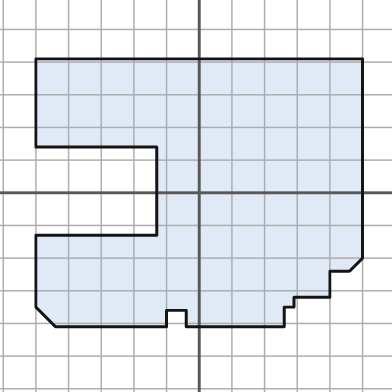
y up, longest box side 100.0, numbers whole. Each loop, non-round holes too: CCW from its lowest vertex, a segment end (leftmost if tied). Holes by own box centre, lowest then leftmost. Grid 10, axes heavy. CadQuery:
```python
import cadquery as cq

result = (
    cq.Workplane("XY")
    .moveTo(-44.0, -41.0)
    .lineTo(-10.0, -41.0)
    .lineTo(-10.0, -36.0)
    .lineTo(-4.0, -36.0)
    .lineTo(-4.0, -41.0)
    .lineTo(26.0, -41.0)
    .lineTo(26.0, -35.0)
    .lineTo(29.0, -35.0)
    .lineTo(29.0, -32.0)
    .lineTo(40.0, -32.0)
    .lineTo(40.0, -24.0)
    .lineTo(46.0, -24.0)
    .lineTo(50.0, -20.0)
    .lineTo(50.0, 41.0)
    .lineTo(-50.0, 41.0)
    .lineTo(-50.0, 14.0)
    .lineTo(-13.0, 14.0)
    .lineTo(-13.0, -13.0)
    .lineTo(-50.0, -13.0)
    .lineTo(-50.0, -35.0)
    .close()
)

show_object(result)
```